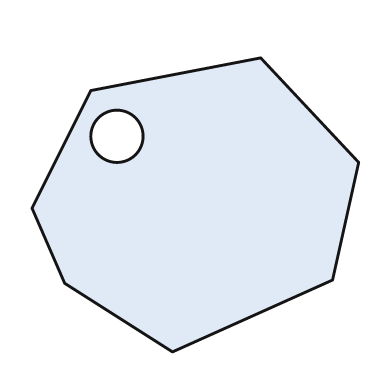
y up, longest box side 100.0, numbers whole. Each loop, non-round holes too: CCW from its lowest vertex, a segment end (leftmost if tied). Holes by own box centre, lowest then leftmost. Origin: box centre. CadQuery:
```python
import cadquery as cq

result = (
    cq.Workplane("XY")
    .moveTo(-7.0, -45.0)
    .lineTo(42.0, -23.0)
    .lineTo(50.0, 13.0)
    .lineTo(20.0, 45.0)
    .lineTo(-32.0, 35.0)
    .lineTo(-50.0, -1.0)
    .lineTo(-40.0, -24.0)
    .close()
    .moveTo(-24.0, 21.0)
    .circle(8.0)
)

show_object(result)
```